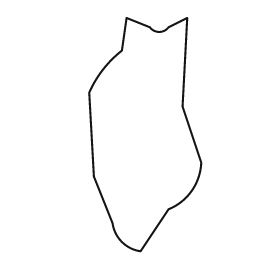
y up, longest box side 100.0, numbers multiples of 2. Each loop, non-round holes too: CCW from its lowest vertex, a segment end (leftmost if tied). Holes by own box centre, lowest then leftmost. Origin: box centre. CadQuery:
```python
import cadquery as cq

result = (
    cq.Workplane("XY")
    .moveTo(-2.0, -50.0)
    .lineTo(10.0, -32.0)
    .threePointArc((20.0, -24.0), (24.0, -12.0))
    .lineTo(16.0, 12.0)
    .lineTo(18.0, 50.0)
    .lineTo(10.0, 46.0)
    .threePointArc((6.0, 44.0), (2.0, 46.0))
    .lineTo(-8.0, 50.0)
    .lineTo(-10.0, 36.0)
    .threePointArc((-18.0, 28.0), (-24.0, 18.0))
    .lineTo(-22.0, -18.0)
    .lineTo(-14.0, -38.0)
    .threePointArc((-10.0, -46.0), (-2.0, -50.0))
    .close()
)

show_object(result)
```